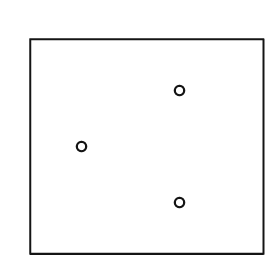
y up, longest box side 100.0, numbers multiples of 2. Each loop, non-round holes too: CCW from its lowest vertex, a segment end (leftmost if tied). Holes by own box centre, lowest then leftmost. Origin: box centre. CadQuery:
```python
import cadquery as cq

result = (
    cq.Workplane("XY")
    .moveTo(-50.0, -46.0)
    .lineTo(50.0, -46.0)
    .lineTo(50.0, 46.0)
    .lineTo(-50.0, 46.0)
    .close()
    .moveTo(14.0, -24.0)
    .circle(2.0)
    .moveTo(-28.0, 0.0)
    .circle(2.0)
    .moveTo(14.0, 24.0)
    .circle(2.0)
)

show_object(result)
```